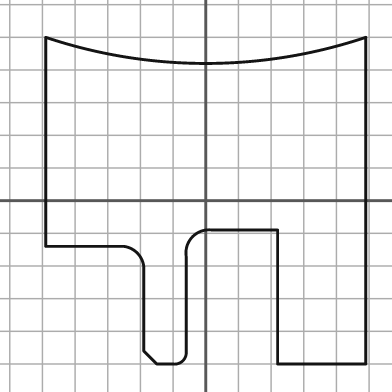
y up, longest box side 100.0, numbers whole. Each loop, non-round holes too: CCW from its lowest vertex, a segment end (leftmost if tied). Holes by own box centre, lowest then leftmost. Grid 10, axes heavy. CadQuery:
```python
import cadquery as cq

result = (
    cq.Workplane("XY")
    .moveTo(-15.0, -50.0)
    .lineTo(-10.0, -50.0)
    .threePointArc((-7.0, -49.0), (-6.0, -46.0))
    .lineTo(-6.0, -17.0)
    .threePointArc((-4.0, -11.0), (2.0, -9.0))
    .lineTo(22.0, -9.0)
    .lineTo(22.0, -50.0)
    .lineTo(49.0, -50.0)
    .lineTo(49.0, 50.0)
    .threePointArc((0.0, 42.0), (-49.0, 50.0))
    .lineTo(-49.0, -14.0)
    .lineTo(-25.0, -14.0)
    .threePointArc((-21.0, -16.0), (-19.0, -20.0))
    .lineTo(-19.0, -46.0)
    .close()
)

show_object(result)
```